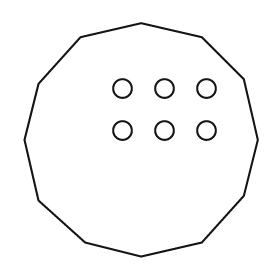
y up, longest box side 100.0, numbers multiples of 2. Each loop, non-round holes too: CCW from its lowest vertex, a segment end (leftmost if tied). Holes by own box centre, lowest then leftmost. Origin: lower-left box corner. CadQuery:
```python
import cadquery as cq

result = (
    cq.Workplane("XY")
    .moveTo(50.0, 0.0)
    .lineTo(76.0, 6.0)
    .lineTo(94.0, 26.0)
    .lineTo(100.0, 50.0)
    .lineTo(94.0, 76.0)
    .lineTo(76.0, 94.0)
    .lineTo(50.0, 100.0)
    .lineTo(24.0, 94.0)
    .lineTo(6.0, 74.0)
    .lineTo(0.0, 50.0)
    .lineTo(6.0, 24.0)
    .lineTo(26.0, 6.0)
    .close()
    .moveTo(42.0, 54.0)
    .circle(4.0)
    .moveTo(60.0, 54.0)
    .circle(4.0)
    .moveTo(78.0, 54.0)
    .circle(4.0)
    .moveTo(42.0, 72.0)
    .circle(4.0)
    .moveTo(60.0, 72.0)
    .circle(4.0)
    .moveTo(78.0, 72.0)
    .circle(4.0)
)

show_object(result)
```